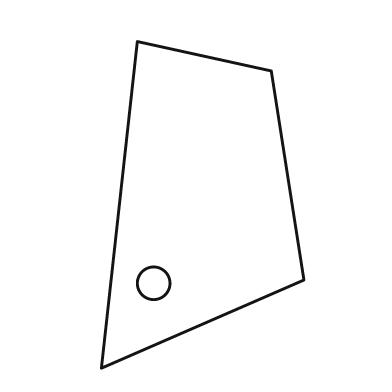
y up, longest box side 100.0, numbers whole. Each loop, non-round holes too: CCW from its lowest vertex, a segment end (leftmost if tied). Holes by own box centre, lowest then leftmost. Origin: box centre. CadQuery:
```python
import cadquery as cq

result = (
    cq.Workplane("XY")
    .moveTo(-31.0, -50.0)
    .lineTo(31.0, -23.0)
    .lineTo(21.0, 41.0)
    .lineTo(-20.0, 50.0)
    .close()
    .moveTo(-15.0, -24.0)
    .circle(5.0)
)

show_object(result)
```